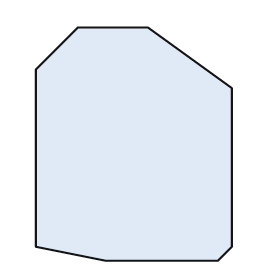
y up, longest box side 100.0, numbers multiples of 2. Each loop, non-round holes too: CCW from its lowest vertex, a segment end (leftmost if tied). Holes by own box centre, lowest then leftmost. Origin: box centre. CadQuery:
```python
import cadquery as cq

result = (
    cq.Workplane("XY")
    .moveTo(-12.0, -50.0)
    .lineTo(36.0, -50.0)
    .lineTo(42.0, -44.0)
    .lineTo(42.0, 24.0)
    .lineTo(6.0, 50.0)
    .lineTo(-24.0, 50.0)
    .lineTo(-42.0, 32.0)
    .lineTo(-42.0, -44.0)
    .close()
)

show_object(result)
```